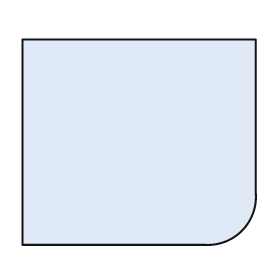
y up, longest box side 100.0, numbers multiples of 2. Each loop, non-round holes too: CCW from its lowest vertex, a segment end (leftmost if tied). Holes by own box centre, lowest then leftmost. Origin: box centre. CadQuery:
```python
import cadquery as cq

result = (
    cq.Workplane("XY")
    .moveTo(-50.0, -44.0)
    .lineTo(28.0, -44.0)
    .threePointArc((44.0, -38.0), (50.0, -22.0))
    .lineTo(50.0, 44.0)
    .lineTo(-50.0, 44.0)
    .close()
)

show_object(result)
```